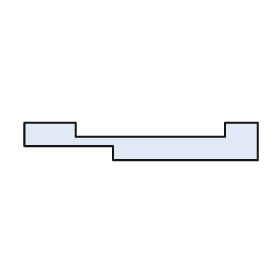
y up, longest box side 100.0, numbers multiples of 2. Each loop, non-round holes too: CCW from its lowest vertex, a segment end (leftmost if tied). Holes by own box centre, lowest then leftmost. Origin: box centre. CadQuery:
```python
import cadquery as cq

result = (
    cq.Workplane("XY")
    .moveTo(-12.0, -8.0)
    .lineTo(50.0, -8.0)
    .lineTo(50.0, 8.0)
    .lineTo(36.0, 8.0)
    .lineTo(36.0, 2.0)
    .lineTo(-28.0, 2.0)
    .lineTo(-28.0, 8.0)
    .lineTo(-50.0, 8.0)
    .lineTo(-50.0, -2.0)
    .lineTo(-12.0, -2.0)
    .close()
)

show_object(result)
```